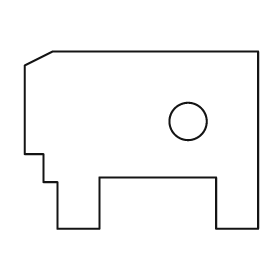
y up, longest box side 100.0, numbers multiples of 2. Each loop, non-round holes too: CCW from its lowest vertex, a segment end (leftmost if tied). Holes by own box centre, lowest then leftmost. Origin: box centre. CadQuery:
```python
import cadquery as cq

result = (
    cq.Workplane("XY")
    .moveTo(-36.0, -38.0)
    .lineTo(-18.0, -38.0)
    .lineTo(-18.0, -16.0)
    .lineTo(32.0, -16.0)
    .lineTo(32.0, -38.0)
    .lineTo(50.0, -38.0)
    .lineTo(50.0, 38.0)
    .lineTo(-38.0, 38.0)
    .lineTo(-50.0, 32.0)
    .lineTo(-50.0, -6.0)
    .lineTo(-42.0, -6.0)
    .lineTo(-42.0, -18.0)
    .lineTo(-36.0, -18.0)
    .close()
    .moveTo(20.0, 8.0)
    .circle(8.0)
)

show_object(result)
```